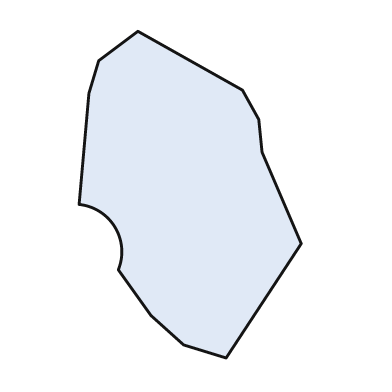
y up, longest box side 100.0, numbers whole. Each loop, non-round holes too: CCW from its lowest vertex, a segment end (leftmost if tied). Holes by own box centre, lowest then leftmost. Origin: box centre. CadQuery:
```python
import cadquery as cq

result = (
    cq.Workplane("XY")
    .moveTo(11.0, -50.0)
    .lineTo(34.0, -15.0)
    .lineTo(22.0, 13.0)
    .lineTo(21.0, 23.0)
    .lineTo(16.0, 32.0)
    .lineTo(-16.0, 50.0)
    .lineTo(-28.0, 41.0)
    .lineTo(-31.0, 31.0)
    .lineTo(-34.0, -3.0)
    .threePointArc((-23.0, -10.0), (-22.0, -23.0))
    .lineTo(-12.0, -37.0)
    .lineTo(-2.0, -46.0)
    .close()
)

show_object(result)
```